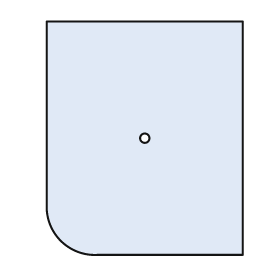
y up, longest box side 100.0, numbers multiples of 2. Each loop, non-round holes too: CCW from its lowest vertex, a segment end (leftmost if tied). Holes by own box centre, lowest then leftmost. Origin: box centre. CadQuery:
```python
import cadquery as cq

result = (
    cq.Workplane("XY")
    .moveTo(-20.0, -50.0)
    .lineTo(42.0, -50.0)
    .lineTo(42.0, 50.0)
    .lineTo(-42.0, 50.0)
    .lineTo(-42.0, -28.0)
    .threePointArc((-36.0, -44.0), (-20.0, -50.0))
    .close()
    .moveTo(0.0, 0.0)
    .circle(2.0)
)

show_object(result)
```